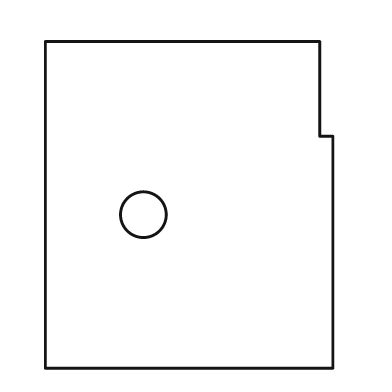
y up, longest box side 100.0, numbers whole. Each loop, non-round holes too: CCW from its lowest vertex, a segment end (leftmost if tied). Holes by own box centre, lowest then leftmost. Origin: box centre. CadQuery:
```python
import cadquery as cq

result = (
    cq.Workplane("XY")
    .moveTo(-44.0, -50.0)
    .lineTo(44.0, -50.0)
    .lineTo(44.0, 21.0)
    .lineTo(40.0, 21.0)
    .lineTo(40.0, 50.0)
    .lineTo(-44.0, 50.0)
    .close()
    .moveTo(-14.0, -3.0)
    .circle(7.0)
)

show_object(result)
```